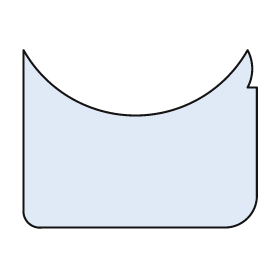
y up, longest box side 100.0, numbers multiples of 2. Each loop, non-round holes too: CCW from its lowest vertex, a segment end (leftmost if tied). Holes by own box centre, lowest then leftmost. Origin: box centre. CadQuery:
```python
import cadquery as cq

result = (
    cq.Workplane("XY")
    .moveTo(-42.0, -38.0)
    .lineTo(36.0, -38.0)
    .threePointArc((46.0, -34.0), (50.0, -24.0))
    .lineTo(50.0, 22.0)
    .lineTo(46.0, 22.0)
    .threePointArc((48.0, 30.0), (46.0, 38.0))
    .threePointArc((-2.0, 10.0), (-50.0, 38.0))
    .lineTo(-50.0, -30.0)
    .threePointArc((-48.0, -36.0), (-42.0, -38.0))
    .close()
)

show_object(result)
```